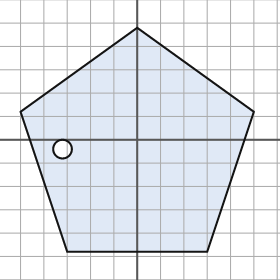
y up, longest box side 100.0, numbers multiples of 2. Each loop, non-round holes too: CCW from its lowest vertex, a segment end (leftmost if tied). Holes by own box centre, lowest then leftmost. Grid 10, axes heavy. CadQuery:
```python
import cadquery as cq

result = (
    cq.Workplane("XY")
    .moveTo(-30.0, -48.0)
    .lineTo(30.0, -48.0)
    .lineTo(50.0, 12.0)
    .lineTo(0.0, 48.0)
    .lineTo(-50.0, 12.0)
    .close()
    .moveTo(-32.0, -4.0)
    .circle(4.0)
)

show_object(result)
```